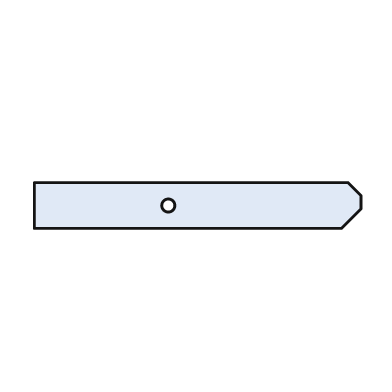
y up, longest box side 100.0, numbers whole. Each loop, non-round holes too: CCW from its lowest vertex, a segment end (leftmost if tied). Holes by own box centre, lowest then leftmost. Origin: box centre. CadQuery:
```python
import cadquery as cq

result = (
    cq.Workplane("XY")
    .moveTo(-50.0, -7.0)
    .lineTo(44.0, -7.0)
    .lineTo(50.0, -1.0)
    .lineTo(50.0, 3.0)
    .lineTo(46.0, 7.0)
    .lineTo(-50.0, 7.0)
    .close()
    .moveTo(-9.0, 0.0)
    .circle(2.0)
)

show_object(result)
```